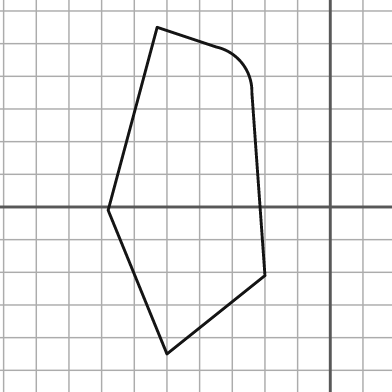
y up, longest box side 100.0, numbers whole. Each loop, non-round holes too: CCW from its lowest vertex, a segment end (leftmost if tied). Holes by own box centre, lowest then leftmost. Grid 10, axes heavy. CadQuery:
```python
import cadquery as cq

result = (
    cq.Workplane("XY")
    .moveTo(-50.0, -45.0)
    .lineTo(-20.0, -21.0)
    .lineTo(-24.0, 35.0)
    .threePointArc((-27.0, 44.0), (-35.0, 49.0))
    .lineTo(-53.0, 55.0)
    .lineTo(-68.0, -1.0)
    .close()
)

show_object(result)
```